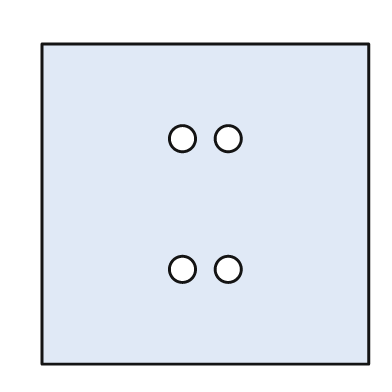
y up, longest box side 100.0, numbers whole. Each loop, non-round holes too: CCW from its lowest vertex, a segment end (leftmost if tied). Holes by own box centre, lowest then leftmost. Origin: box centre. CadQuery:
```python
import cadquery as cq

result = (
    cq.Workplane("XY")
    .moveTo(-50.0, -49.0)
    .lineTo(50.0, -49.0)
    .lineTo(50.0, 49.0)
    .lineTo(-50.0, 49.0)
    .close()
    .moveTo(-7.0, -20.0)
    .circle(4.0)
    .moveTo(7.0, -20.0)
    .circle(4.0)
    .moveTo(-7.0, 20.0)
    .circle(4.0)
    .moveTo(7.0, 20.0)
    .circle(4.0)
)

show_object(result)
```